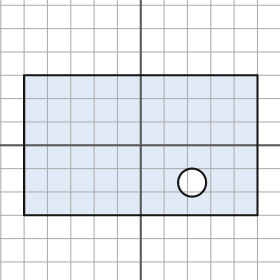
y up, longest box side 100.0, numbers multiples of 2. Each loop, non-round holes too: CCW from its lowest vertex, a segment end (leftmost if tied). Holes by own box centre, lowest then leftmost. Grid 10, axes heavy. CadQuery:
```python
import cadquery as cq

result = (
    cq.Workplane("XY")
    .moveTo(-50.0, -30.0)
    .lineTo(50.0, -30.0)
    .lineTo(50.0, 30.0)
    .lineTo(-50.0, 30.0)
    .close()
    .moveTo(22.0, -16.0)
    .circle(6.0)
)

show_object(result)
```